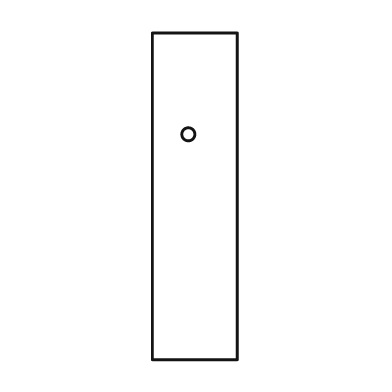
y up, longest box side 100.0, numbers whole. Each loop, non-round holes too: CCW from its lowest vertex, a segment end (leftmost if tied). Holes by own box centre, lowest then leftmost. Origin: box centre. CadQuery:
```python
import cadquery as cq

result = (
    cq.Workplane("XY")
    .moveTo(-13.0, -50.0)
    .lineTo(13.0, -50.0)
    .lineTo(13.0, 50.0)
    .lineTo(-13.0, 50.0)
    .close()
    .moveTo(-2.0, 19.0)
    .circle(2.0)
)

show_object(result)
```